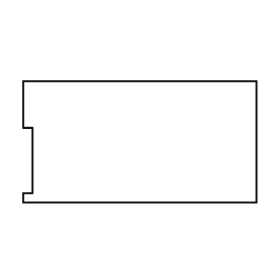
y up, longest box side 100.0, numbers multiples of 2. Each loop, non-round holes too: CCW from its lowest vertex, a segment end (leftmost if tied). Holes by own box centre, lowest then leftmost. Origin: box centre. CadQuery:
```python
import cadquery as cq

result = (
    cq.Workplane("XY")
    .moveTo(-50.0, -26.0)
    .lineTo(50.0, -26.0)
    .lineTo(50.0, 26.0)
    .lineTo(-50.0, 26.0)
    .lineTo(-50.0, 6.0)
    .lineTo(-46.0, 6.0)
    .lineTo(-46.0, -22.0)
    .lineTo(-50.0, -22.0)
    .close()
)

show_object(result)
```